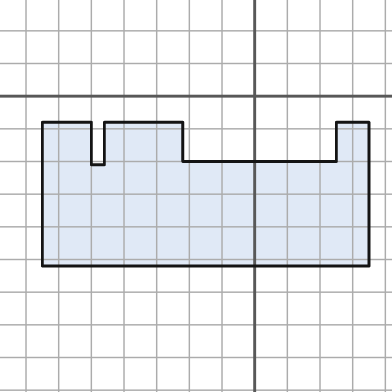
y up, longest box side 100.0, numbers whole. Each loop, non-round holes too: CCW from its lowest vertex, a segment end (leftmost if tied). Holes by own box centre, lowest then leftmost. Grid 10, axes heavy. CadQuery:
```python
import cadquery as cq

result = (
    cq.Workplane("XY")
    .moveTo(-65.0, -52.0)
    .lineTo(35.0, -52.0)
    .lineTo(35.0, -8.0)
    .lineTo(25.0, -8.0)
    .lineTo(25.0, -20.0)
    .lineTo(-22.0, -20.0)
    .lineTo(-22.0, -8.0)
    .lineTo(-46.0, -8.0)
    .lineTo(-46.0, -21.0)
    .lineTo(-50.0, -21.0)
    .lineTo(-50.0, -8.0)
    .lineTo(-65.0, -8.0)
    .close()
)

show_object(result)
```